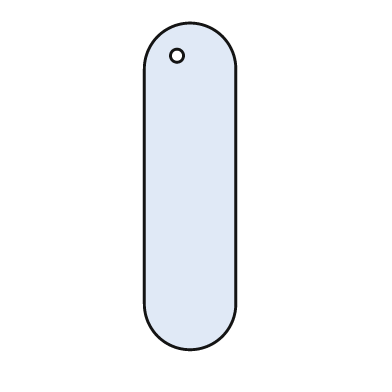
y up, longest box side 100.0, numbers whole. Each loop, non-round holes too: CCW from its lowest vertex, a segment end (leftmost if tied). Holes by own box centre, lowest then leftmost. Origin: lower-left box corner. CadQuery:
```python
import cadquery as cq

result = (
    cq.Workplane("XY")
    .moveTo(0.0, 14.0)
    .threePointArc((14.0, 0.0), (28.0, 14.0))
    .lineTo(28.0, 86.0)
    .threePointArc((14.0, 100.0), (0.0, 86.0))
    .close()
    .moveTo(10.0, 90.0)
    .circle(2.0)
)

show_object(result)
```